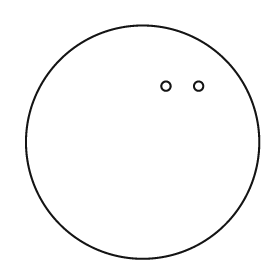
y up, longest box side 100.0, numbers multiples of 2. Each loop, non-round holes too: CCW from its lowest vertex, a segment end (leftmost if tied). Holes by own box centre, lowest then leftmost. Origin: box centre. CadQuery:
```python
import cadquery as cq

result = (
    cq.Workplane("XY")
    .moveTo(0.0, 0.0)
    .circle(50.0)
    .moveTo(10.0, 24.0)
    .circle(2.0)
    .moveTo(24.0, 24.0)
    .circle(2.0)
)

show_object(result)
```